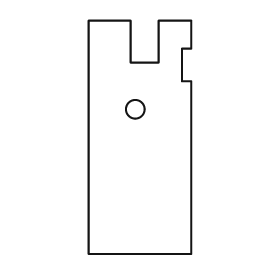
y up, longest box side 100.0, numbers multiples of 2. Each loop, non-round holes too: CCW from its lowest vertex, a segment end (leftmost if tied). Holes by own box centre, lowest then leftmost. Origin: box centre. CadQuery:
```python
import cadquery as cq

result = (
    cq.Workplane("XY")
    .moveTo(-22.0, -50.0)
    .lineTo(22.0, -50.0)
    .lineTo(22.0, 24.0)
    .lineTo(18.0, 24.0)
    .lineTo(18.0, 38.0)
    .lineTo(22.0, 38.0)
    .lineTo(22.0, 50.0)
    .lineTo(8.0, 50.0)
    .lineTo(8.0, 32.0)
    .lineTo(-4.0, 32.0)
    .lineTo(-4.0, 50.0)
    .lineTo(-22.0, 50.0)
    .close()
    .moveTo(-2.0, 12.0)
    .circle(4.0)
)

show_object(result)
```